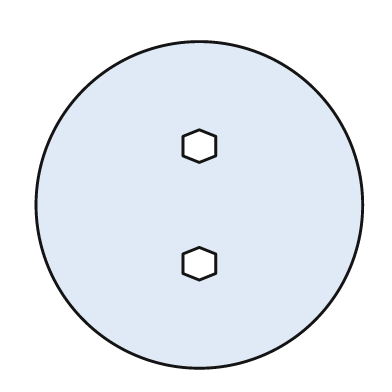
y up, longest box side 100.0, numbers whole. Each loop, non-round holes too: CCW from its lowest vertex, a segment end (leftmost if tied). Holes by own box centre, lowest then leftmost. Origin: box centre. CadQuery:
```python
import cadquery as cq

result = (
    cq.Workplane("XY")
    .moveTo(0.0, 0.0)
    .circle(50.0)
    .moveTo(0.0, -23.0)
    .lineTo(5.0, -21.0)
    .lineTo(5.0, -15.0)
    .lineTo(0.0, -13.0)
    .lineTo(-5.0, -15.0)
    .lineTo(-5.0, -21.0)
    .close()
    .moveTo(0.0, 13.0)
    .lineTo(5.0, 15.0)
    .lineTo(5.0, 21.0)
    .lineTo(0.0, 23.0)
    .lineTo(-5.0, 21.0)
    .lineTo(-5.0, 15.0)
    .close()
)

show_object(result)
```